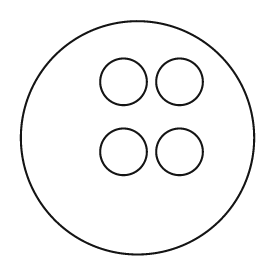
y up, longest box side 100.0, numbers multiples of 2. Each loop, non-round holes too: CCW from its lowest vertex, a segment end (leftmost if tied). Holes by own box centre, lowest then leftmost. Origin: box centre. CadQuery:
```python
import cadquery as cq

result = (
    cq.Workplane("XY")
    .moveTo(0.0, 0.0)
    .circle(50.0)
    .moveTo(-6.0, -6.0)
    .circle(10.0)
    .moveTo(18.0, -6.0)
    .circle(10.0)
    .moveTo(-6.0, 24.0)
    .circle(10.0)
    .moveTo(18.0, 24.0)
    .circle(10.0)
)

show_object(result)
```